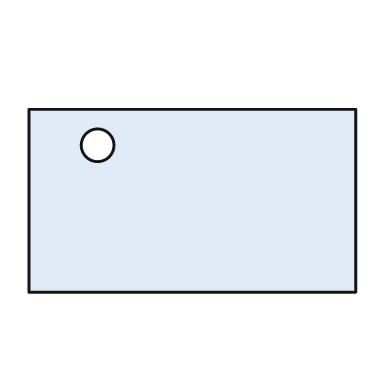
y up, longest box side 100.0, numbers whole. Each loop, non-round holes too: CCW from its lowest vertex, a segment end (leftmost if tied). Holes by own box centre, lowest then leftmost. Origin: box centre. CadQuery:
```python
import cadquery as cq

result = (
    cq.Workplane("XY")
    .moveTo(-50.0, -28.0)
    .lineTo(50.0, -28.0)
    .lineTo(50.0, 28.0)
    .lineTo(-50.0, 28.0)
    .close()
    .moveTo(-29.0, 17.0)
    .circle(5.0)
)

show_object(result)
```